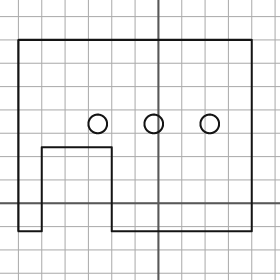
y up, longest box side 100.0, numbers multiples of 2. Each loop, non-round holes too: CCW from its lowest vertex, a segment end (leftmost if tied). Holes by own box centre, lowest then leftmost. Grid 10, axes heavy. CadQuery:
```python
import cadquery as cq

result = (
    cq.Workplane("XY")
    .moveTo(-60.0, -12.0)
    .lineTo(-50.0, -12.0)
    .lineTo(-50.0, 24.0)
    .lineTo(-20.0, 24.0)
    .lineTo(-20.0, -12.0)
    .lineTo(40.0, -12.0)
    .lineTo(40.0, 70.0)
    .lineTo(-60.0, 70.0)
    .close()
    .moveTo(-26.0, 34.0)
    .circle(4.0)
    .moveTo(-2.0, 34.0)
    .circle(4.0)
    .moveTo(22.0, 34.0)
    .circle(4.0)
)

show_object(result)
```